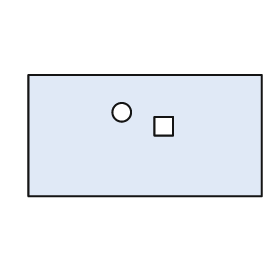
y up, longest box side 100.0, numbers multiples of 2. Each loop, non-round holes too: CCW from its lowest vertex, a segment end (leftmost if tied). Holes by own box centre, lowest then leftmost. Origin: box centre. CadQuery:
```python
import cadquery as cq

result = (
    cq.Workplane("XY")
    .moveTo(-50.0, -26.0)
    .lineTo(50.0, -26.0)
    .lineTo(50.0, 26.0)
    .lineTo(-50.0, 26.0)
    .close()
    .moveTo(4.0, 0.0)
    .lineTo(12.0, 0.0)
    .lineTo(12.0, 8.0)
    .lineTo(4.0, 8.0)
    .close()
    .moveTo(-10.0, 10.0)
    .circle(4.0)
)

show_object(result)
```